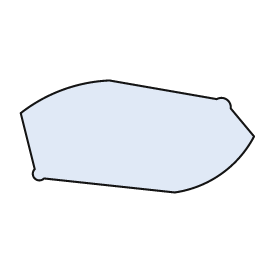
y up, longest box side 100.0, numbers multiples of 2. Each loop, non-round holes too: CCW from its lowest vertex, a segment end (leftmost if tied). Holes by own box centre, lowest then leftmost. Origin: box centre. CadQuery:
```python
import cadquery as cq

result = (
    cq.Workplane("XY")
    .moveTo(16.0, -24.0)
    .threePointArc((36.0, -16.0), (50.0, 0.0))
    .lineTo(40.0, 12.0)
    .threePointArc((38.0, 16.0), (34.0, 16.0))
    .lineTo(-12.0, 24.0)
    .threePointArc((-32.0, 20.0), (-50.0, 10.0))
    .lineTo(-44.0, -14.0)
    .threePointArc((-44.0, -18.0), (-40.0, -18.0))
    .close()
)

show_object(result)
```